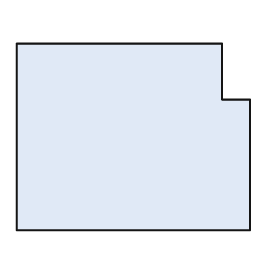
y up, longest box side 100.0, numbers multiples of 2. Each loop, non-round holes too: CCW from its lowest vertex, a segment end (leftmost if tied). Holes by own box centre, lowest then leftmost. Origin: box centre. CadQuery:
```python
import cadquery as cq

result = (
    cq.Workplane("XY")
    .moveTo(-50.0, -40.0)
    .lineTo(50.0, -40.0)
    .lineTo(50.0, 16.0)
    .lineTo(38.0, 16.0)
    .lineTo(38.0, 40.0)
    .lineTo(-50.0, 40.0)
    .close()
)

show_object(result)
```